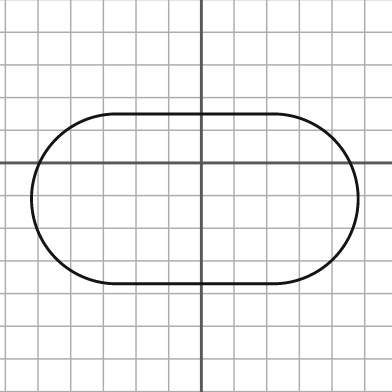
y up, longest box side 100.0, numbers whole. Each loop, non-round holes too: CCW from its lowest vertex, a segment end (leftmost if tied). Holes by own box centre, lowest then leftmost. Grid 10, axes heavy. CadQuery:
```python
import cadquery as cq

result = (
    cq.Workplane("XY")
    .moveTo(-26.0, -37.0)
    .lineTo(22.0, -37.0)
    .threePointArc((48.0, -11.0), (22.0, 15.0))
    .lineTo(-26.0, 15.0)
    .threePointArc((-52.0, -11.0), (-26.0, -37.0))
    .close()
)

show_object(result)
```